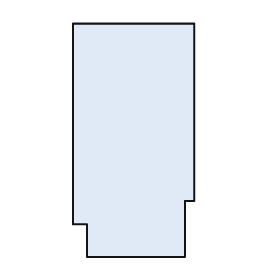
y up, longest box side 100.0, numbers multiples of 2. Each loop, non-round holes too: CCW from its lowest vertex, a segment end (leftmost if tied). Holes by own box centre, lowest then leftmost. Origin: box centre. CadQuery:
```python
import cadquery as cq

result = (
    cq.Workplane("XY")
    .moveTo(-20.0, -50.0)
    .lineTo(22.0, -50.0)
    .lineTo(22.0, -26.0)
    .lineTo(26.0, -26.0)
    .lineTo(26.0, 50.0)
    .lineTo(-26.0, 50.0)
    .lineTo(-26.0, -36.0)
    .lineTo(-20.0, -36.0)
    .close()
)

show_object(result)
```